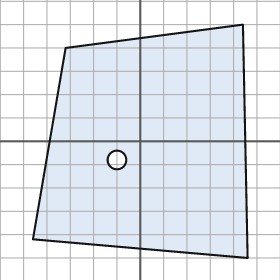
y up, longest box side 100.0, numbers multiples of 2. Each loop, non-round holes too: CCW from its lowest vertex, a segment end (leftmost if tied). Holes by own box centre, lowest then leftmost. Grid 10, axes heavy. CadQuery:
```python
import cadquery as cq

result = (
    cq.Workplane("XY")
    .moveTo(46.0, -50.0)
    .lineTo(44.0, 50.0)
    .lineTo(-32.0, 40.0)
    .lineTo(-46.0, -42.0)
    .close()
    .moveTo(-10.0, -8.0)
    .circle(4.0)
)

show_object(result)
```